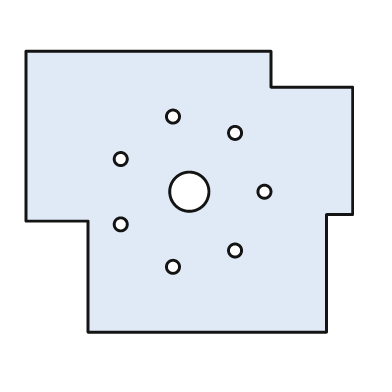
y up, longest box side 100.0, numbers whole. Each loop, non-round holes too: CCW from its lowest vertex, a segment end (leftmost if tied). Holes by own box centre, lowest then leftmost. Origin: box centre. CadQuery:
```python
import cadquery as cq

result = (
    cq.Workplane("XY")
    .moveTo(-31.0, -43.0)
    .lineTo(42.0, -43.0)
    .lineTo(42.0, -7.0)
    .lineTo(50.0, -7.0)
    .lineTo(50.0, 32.0)
    .lineTo(25.0, 32.0)
    .lineTo(25.0, 43.0)
    .lineTo(-50.0, 43.0)
    .lineTo(-50.0, -9.0)
    .lineTo(-31.0, -9.0)
    .close()
    .moveTo(-5.0, -23.0)
    .circle(2.0)
    .moveTo(14.0, -18.0)
    .circle(2.0)
    .moveTo(-21.0, -10.0)
    .circle(2.0)
    .moveTo(0.0, 0.0)
    .circle(6.0)
    .moveTo(23.0, 0.0)
    .circle(2.0)
    .moveTo(-21.0, 10.0)
    .circle(2.0)
    .moveTo(14.0, 18.0)
    .circle(2.0)
    .moveTo(-5.0, 23.0)
    .circle(2.0)
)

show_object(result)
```